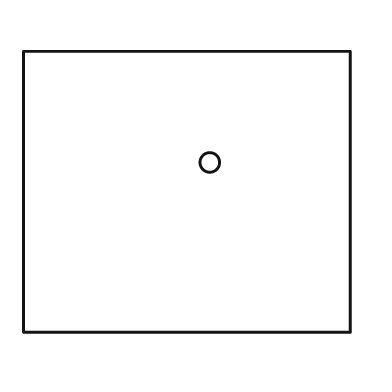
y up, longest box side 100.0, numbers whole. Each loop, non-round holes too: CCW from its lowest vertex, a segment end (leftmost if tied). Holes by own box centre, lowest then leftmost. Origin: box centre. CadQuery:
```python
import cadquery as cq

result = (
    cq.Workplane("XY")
    .moveTo(-50.0, -43.0)
    .lineTo(50.0, -43.0)
    .lineTo(50.0, 43.0)
    .lineTo(-50.0, 43.0)
    .close()
    .moveTo(7.0, 9.0)
    .circle(3.0)
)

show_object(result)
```